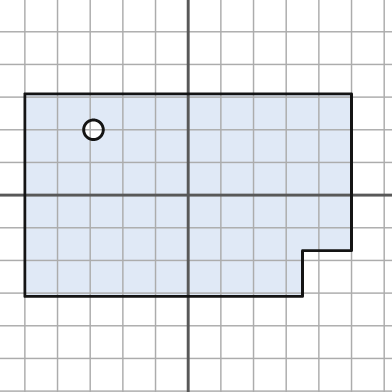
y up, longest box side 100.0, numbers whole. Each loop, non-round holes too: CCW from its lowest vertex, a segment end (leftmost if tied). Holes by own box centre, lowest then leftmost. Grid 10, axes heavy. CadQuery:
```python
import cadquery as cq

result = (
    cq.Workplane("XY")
    .moveTo(-50.0, -31.0)
    .lineTo(35.0, -31.0)
    .lineTo(35.0, -17.0)
    .lineTo(50.0, -17.0)
    .lineTo(50.0, 31.0)
    .lineTo(-50.0, 31.0)
    .close()
    .moveTo(-29.0, 20.0)
    .circle(3.0)
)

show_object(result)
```